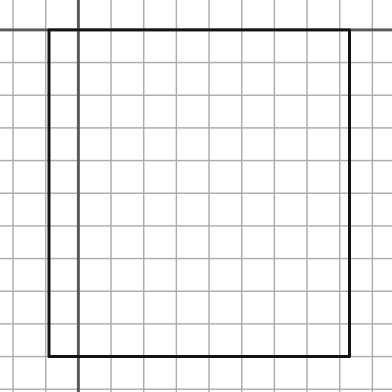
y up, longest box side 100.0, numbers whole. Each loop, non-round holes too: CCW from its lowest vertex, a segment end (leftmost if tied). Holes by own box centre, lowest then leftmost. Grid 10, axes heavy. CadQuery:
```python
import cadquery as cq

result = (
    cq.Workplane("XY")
    .moveTo(-9.0, -100.0)
    .lineTo(83.0, -100.0)
    .lineTo(83.0, 0.0)
    .lineTo(-9.0, 0.0)
    .close()
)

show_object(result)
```